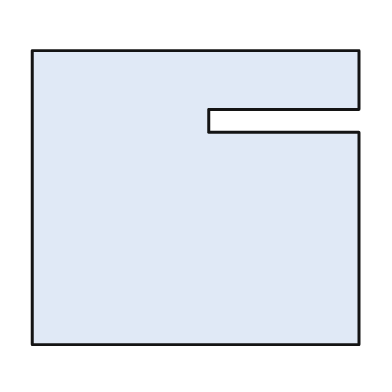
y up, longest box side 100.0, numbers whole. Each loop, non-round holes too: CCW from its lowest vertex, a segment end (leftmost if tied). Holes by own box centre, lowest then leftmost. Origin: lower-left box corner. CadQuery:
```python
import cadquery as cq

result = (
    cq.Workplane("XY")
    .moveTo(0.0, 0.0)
    .lineTo(100.0, 0.0)
    .lineTo(100.0, 65.0)
    .lineTo(54.0, 65.0)
    .lineTo(54.0, 72.0)
    .lineTo(100.0, 72.0)
    .lineTo(100.0, 90.0)
    .lineTo(0.0, 90.0)
    .close()
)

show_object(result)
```